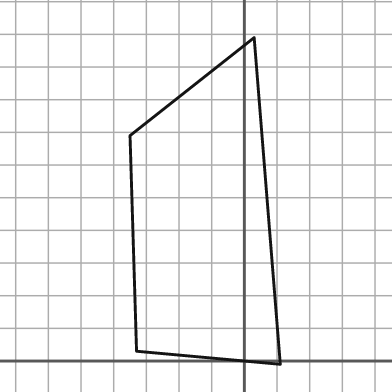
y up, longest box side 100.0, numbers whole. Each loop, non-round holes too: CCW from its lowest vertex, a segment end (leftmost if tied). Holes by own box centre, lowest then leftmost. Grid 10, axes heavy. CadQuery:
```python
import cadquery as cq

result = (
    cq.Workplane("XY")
    .moveTo(11.0, -1.0)
    .lineTo(3.0, 99.0)
    .lineTo(-35.0, 69.0)
    .lineTo(-33.0, 3.0)
    .close()
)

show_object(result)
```